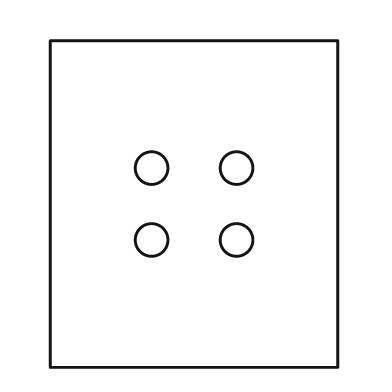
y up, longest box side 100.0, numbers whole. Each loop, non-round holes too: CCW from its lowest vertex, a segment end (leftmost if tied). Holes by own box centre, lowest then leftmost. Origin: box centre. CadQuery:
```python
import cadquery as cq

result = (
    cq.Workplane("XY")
    .moveTo(-44.0, -50.0)
    .lineTo(44.0, -50.0)
    .lineTo(44.0, 50.0)
    .lineTo(-44.0, 50.0)
    .close()
    .moveTo(-13.0, -11.0)
    .circle(5.0)
    .moveTo(13.0, -11.0)
    .circle(5.0)
    .moveTo(-13.0, 11.0)
    .circle(5.0)
    .moveTo(13.0, 11.0)
    .circle(5.0)
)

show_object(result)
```